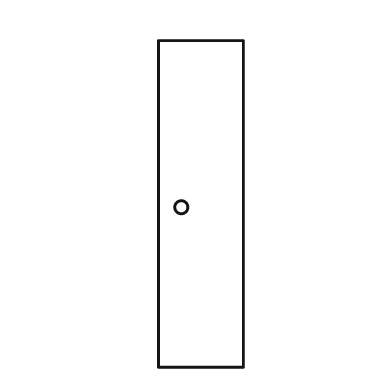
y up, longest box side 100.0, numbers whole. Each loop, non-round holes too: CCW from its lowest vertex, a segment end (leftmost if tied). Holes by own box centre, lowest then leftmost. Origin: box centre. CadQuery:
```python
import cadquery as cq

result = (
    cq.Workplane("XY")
    .moveTo(-13.0, -50.0)
    .lineTo(13.0, -50.0)
    .lineTo(13.0, 50.0)
    .lineTo(-13.0, 50.0)
    .close()
    .moveTo(-6.0, -1.0)
    .circle(2.0)
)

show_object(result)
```